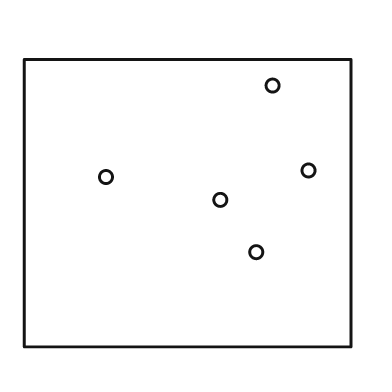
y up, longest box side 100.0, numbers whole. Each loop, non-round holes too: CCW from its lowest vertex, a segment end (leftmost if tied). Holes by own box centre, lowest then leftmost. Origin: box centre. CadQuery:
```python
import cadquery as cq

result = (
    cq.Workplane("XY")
    .moveTo(-50.0, -44.0)
    .lineTo(50.0, -44.0)
    .lineTo(50.0, 44.0)
    .lineTo(-50.0, 44.0)
    .close()
    .moveTo(21.0, -15.0)
    .circle(2.0)
    .moveTo(10.0, 1.0)
    .circle(2.0)
    .moveTo(-25.0, 8.0)
    .circle(2.0)
    .moveTo(37.0, 10.0)
    .circle(2.0)
    .moveTo(26.0, 36.0)
    .circle(2.0)
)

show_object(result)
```